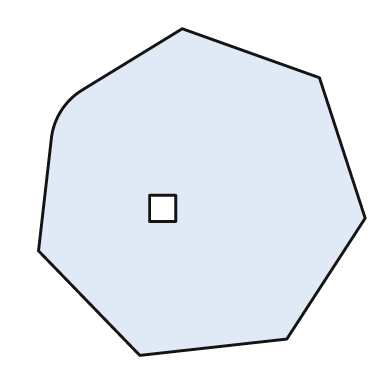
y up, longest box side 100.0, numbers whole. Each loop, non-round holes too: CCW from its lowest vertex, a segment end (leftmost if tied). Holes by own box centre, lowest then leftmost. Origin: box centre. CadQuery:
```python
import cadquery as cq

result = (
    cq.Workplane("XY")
    .moveTo(-19.0, -50.0)
    .lineTo(26.0, -45.0)
    .lineTo(50.0, -8.0)
    .lineTo(36.0, 35.0)
    .lineTo(-6.0, 50.0)
    .lineTo(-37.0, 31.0)
    .threePointArc((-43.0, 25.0), (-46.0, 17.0))
    .lineTo(-50.0, -18.0)
    .close()
    .moveTo(-16.0, -9.0)
    .lineTo(-8.0, -9.0)
    .lineTo(-8.0, -1.0)
    .lineTo(-16.0, -1.0)
    .close()
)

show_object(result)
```